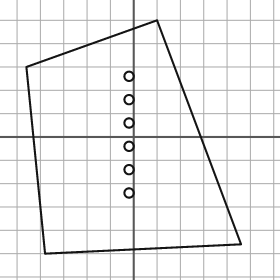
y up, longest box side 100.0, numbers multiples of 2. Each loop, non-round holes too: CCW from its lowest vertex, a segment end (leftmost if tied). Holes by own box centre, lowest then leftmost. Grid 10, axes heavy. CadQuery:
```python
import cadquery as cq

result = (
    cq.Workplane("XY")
    .moveTo(-38.0, -50.0)
    .lineTo(46.0, -46.0)
    .lineTo(10.0, 50.0)
    .lineTo(-46.0, 30.0)
    .close()
    .moveTo(-2.0, -24.0)
    .circle(2.0)
    .moveTo(-2.0, -14.0)
    .circle(2.0)
    .moveTo(-2.0, -4.0)
    .circle(2.0)
    .moveTo(-2.0, 6.0)
    .circle(2.0)
    .moveTo(-2.0, 16.0)
    .circle(2.0)
    .moveTo(-2.0, 26.0)
    .circle(2.0)
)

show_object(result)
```